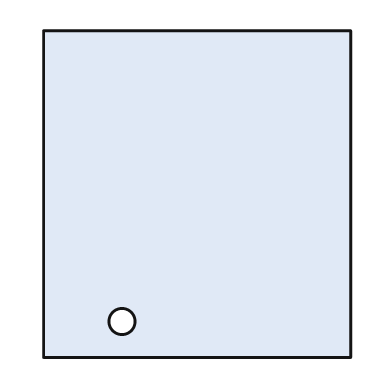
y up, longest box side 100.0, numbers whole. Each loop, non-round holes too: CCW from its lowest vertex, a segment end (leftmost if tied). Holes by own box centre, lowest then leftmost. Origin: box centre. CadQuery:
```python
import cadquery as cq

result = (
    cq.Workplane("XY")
    .moveTo(-47.0, -50.0)
    .lineTo(47.0, -50.0)
    .lineTo(47.0, 50.0)
    .lineTo(-47.0, 50.0)
    .close()
    .moveTo(-23.0, -39.0)
    .circle(4.0)
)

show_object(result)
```